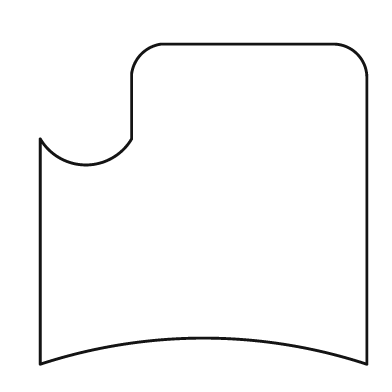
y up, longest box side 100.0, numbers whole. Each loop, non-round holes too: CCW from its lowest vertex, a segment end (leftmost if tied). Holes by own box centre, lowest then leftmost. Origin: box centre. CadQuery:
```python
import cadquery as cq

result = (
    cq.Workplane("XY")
    .moveTo(-50.0, -49.0)
    .threePointArc((0.0, -41.0), (50.0, -49.0))
    .lineTo(50.0, 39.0)
    .threePointArc((47.0, 46.0), (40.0, 49.0))
    .lineTo(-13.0, 49.0)
    .threePointArc((-19.0, 46.0), (-22.0, 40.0))
    .lineTo(-22.0, 20.0)
    .threePointArc((-36.0, 12.0), (-50.0, 20.0))
    .close()
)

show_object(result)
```